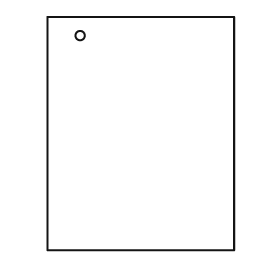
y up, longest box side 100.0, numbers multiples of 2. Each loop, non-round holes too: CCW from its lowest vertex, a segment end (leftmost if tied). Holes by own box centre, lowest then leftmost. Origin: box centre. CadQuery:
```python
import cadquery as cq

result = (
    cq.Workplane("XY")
    .moveTo(-40.0, -50.0)
    .lineTo(40.0, -50.0)
    .lineTo(40.0, 50.0)
    .lineTo(-40.0, 50.0)
    .close()
    .moveTo(-26.0, 42.0)
    .circle(2.0)
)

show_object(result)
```